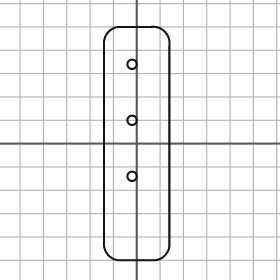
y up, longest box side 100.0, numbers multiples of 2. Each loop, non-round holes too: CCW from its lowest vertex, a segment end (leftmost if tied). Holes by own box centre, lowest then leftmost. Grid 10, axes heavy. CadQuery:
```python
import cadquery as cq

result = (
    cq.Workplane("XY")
    .moveTo(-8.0, -50.0)
    .lineTo(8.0, -50.0)
    .threePointArc((12.0, -48.0), (14.0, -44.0))
    .lineTo(14.0, 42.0)
    .threePointArc((12.0, 48.0), (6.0, 50.0))
    .lineTo(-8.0, 50.0)
    .threePointArc((-12.0, 48.0), (-14.0, 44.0))
    .lineTo(-14.0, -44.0)
    .threePointArc((-12.0, -48.0), (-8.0, -50.0))
    .close()
    .moveTo(-2.0, -14.0)
    .circle(2.0)
    .moveTo(-2.0, 10.0)
    .circle(2.0)
    .moveTo(-2.0, 34.0)
    .circle(2.0)
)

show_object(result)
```